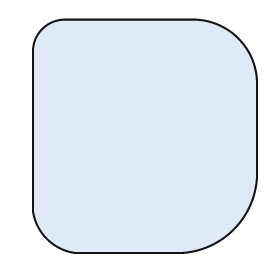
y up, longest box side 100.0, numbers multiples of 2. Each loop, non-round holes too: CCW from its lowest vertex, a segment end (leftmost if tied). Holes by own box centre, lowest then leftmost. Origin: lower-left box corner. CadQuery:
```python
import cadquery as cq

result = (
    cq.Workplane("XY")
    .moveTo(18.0, 0.0)
    .lineTo(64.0, 0.0)
    .threePointArc((86.0, 10.0), (96.0, 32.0))
    .lineTo(96.0, 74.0)
    .threePointArc((88.0, 92.0), (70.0, 100.0))
    .lineTo(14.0, 100.0)
    .threePointArc((4.0, 96.0), (0.0, 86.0))
    .lineTo(0.0, 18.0)
    .threePointArc((6.0, 6.0), (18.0, 0.0))
    .close()
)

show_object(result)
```